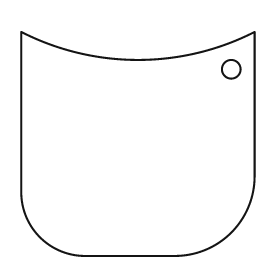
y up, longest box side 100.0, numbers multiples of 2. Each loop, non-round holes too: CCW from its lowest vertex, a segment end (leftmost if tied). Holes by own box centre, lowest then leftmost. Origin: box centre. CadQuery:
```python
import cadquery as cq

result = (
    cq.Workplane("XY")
    .moveTo(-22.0, -48.0)
    .lineTo(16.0, -48.0)
    .threePointArc((40.0, -38.0), (50.0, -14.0))
    .lineTo(50.0, 48.0)
    .threePointArc((0.0, 36.0), (-50.0, 48.0))
    .lineTo(-50.0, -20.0)
    .threePointArc((-42.0, -40.0), (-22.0, -48.0))
    .close()
    .moveTo(40.0, 32.0)
    .circle(4.0)
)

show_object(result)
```